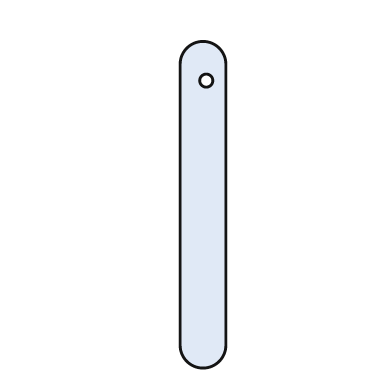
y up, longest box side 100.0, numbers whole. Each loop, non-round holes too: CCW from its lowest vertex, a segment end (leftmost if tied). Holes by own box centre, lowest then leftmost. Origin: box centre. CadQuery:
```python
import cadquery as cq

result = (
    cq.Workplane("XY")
    .moveTo(-7.0, -43.0)
    .threePointArc((0.0, -50.0), (7.0, -43.0))
    .lineTo(7.0, 43.0)
    .threePointArc((0.0, 50.0), (-7.0, 43.0))
    .close()
    .moveTo(1.0, 38.0)
    .circle(2.0)
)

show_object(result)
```